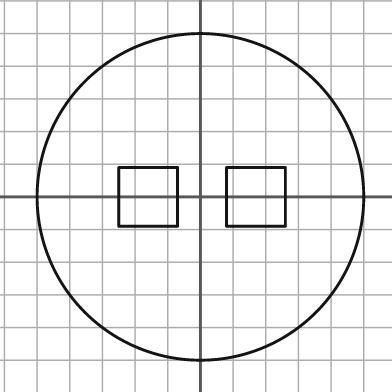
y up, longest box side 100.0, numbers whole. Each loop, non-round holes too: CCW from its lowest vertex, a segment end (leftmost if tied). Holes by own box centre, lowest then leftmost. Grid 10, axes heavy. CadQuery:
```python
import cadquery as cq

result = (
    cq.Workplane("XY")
    .moveTo(0.0, 0.0)
    .circle(50.0)
    .moveTo(-25.0, -9.0)
    .lineTo(-7.0, -9.0)
    .lineTo(-7.0, 9.0)
    .lineTo(-25.0, 9.0)
    .close()
    .moveTo(8.0, -9.0)
    .lineTo(26.0, -9.0)
    .lineTo(26.0, 9.0)
    .lineTo(8.0, 9.0)
    .close()
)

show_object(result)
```